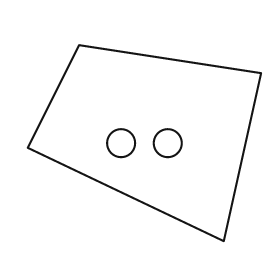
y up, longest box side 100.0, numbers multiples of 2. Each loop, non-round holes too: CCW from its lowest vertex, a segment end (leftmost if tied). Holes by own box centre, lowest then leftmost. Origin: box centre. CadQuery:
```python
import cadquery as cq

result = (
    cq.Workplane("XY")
    .moveTo(34.0, -42.0)
    .lineTo(50.0, 30.0)
    .lineTo(-28.0, 42.0)
    .lineTo(-50.0, -2.0)
    .close()
    .moveTo(-10.0, 0.0)
    .circle(6.0)
    .moveTo(10.0, 0.0)
    .circle(6.0)
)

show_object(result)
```